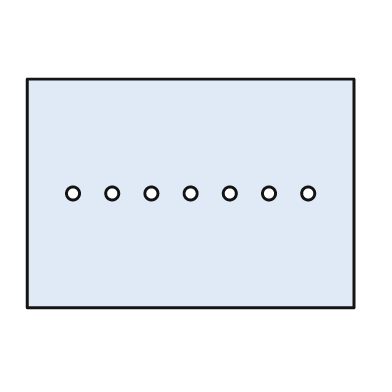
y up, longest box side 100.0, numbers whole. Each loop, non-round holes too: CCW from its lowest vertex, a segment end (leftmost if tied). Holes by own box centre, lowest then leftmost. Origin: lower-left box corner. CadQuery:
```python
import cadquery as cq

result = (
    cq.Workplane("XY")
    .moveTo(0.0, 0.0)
    .lineTo(100.0, 0.0)
    .lineTo(100.0, 70.0)
    .lineTo(0.0, 70.0)
    .close()
    .moveTo(14.0, 35.0)
    .circle(2.0)
    .moveTo(26.0, 35.0)
    .circle(2.0)
    .moveTo(38.0, 35.0)
    .circle(2.0)
    .moveTo(50.0, 35.0)
    .circle(2.0)
    .moveTo(62.0, 35.0)
    .circle(2.0)
    .moveTo(74.0, 35.0)
    .circle(2.0)
    .moveTo(86.0, 35.0)
    .circle(2.0)
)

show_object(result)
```